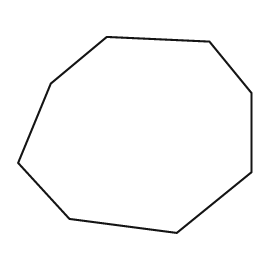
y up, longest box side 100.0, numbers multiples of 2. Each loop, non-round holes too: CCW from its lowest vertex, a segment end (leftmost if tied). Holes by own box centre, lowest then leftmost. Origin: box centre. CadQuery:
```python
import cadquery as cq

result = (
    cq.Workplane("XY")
    .moveTo(18.0, -42.0)
    .lineTo(50.0, -16.0)
    .lineTo(50.0, 18.0)
    .lineTo(32.0, 40.0)
    .lineTo(-12.0, 42.0)
    .lineTo(-36.0, 22.0)
    .lineTo(-50.0, -12.0)
    .lineTo(-28.0, -36.0)
    .close()
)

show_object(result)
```